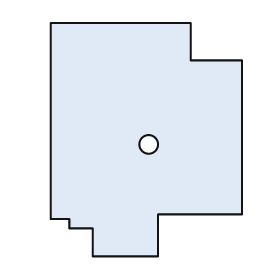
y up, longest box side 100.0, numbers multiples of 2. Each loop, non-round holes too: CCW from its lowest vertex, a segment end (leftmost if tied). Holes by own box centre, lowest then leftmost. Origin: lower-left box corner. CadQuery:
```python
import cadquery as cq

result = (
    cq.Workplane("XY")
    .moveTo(18.0, 0.0)
    .lineTo(46.0, 0.0)
    .lineTo(46.0, 18.0)
    .lineTo(82.0, 18.0)
    .lineTo(82.0, 84.0)
    .lineTo(60.0, 84.0)
    .lineTo(60.0, 100.0)
    .lineTo(0.0, 100.0)
    .lineTo(0.0, 16.0)
    .lineTo(8.0, 16.0)
    .lineTo(8.0, 12.0)
    .lineTo(18.0, 12.0)
    .close()
    .moveTo(42.0, 48.0)
    .circle(4.0)
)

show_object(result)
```